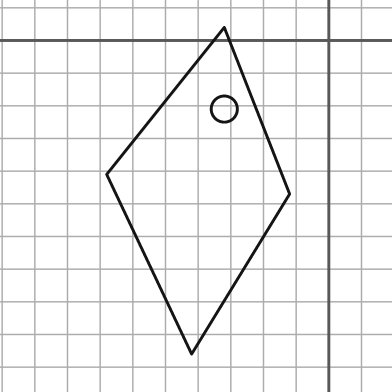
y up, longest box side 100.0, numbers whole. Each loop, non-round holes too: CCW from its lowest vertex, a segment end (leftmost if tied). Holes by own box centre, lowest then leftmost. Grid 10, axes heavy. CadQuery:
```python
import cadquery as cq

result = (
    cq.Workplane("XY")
    .moveTo(-42.0, -96.0)
    .lineTo(-12.0, -47.0)
    .lineTo(-32.0, 4.0)
    .lineTo(-68.0, -41.0)
    .close()
    .moveTo(-32.0, -21.0)
    .circle(4.0)
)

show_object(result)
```